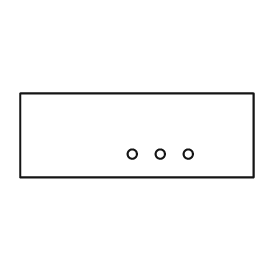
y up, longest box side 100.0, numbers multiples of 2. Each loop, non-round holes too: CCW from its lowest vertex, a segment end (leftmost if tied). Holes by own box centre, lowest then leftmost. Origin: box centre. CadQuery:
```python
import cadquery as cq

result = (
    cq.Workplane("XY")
    .moveTo(-50.0, -18.0)
    .lineTo(50.0, -18.0)
    .lineTo(50.0, 18.0)
    .lineTo(-50.0, 18.0)
    .close()
    .moveTo(-2.0, -8.0)
    .circle(2.0)
    .moveTo(10.0, -8.0)
    .circle(2.0)
    .moveTo(22.0, -8.0)
    .circle(2.0)
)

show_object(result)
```